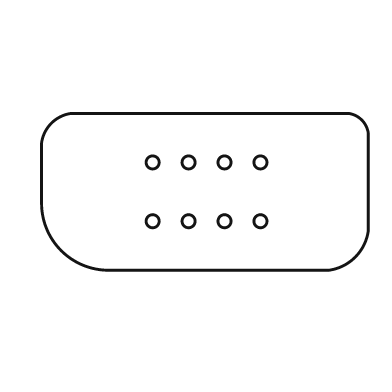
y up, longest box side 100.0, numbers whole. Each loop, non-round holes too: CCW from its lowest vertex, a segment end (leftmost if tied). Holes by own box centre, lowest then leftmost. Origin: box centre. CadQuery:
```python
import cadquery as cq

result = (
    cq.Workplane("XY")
    .moveTo(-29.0, -24.0)
    .lineTo(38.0, -24.0)
    .threePointArc((46.0, -20.0), (50.0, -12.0))
    .lineTo(50.0, 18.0)
    .threePointArc((48.0, 22.0), (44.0, 24.0))
    .lineTo(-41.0, 24.0)
    .threePointArc((-47.0, 21.0), (-50.0, 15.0))
    .lineTo(-50.0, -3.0)
    .threePointArc((-44.0, -18.0), (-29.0, -24.0))
    .close()
    .moveTo(-16.0, -9.0)
    .circle(2.0)
    .moveTo(-5.0, -9.0)
    .circle(2.0)
    .moveTo(6.0, -9.0)
    .circle(2.0)
    .moveTo(17.0, -9.0)
    .circle(2.0)
    .moveTo(-16.0, 9.0)
    .circle(2.0)
    .moveTo(-5.0, 9.0)
    .circle(2.0)
    .moveTo(6.0, 9.0)
    .circle(2.0)
    .moveTo(17.0, 9.0)
    .circle(2.0)
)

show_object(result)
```